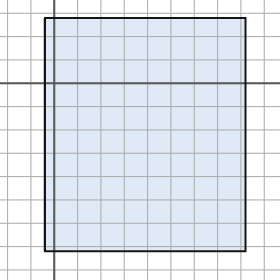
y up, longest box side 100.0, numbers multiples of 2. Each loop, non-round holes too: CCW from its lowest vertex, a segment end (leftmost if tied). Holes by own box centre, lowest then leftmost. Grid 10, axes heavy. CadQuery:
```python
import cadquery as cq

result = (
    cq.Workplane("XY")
    .moveTo(-4.0, -72.0)
    .lineTo(82.0, -72.0)
    .lineTo(82.0, 28.0)
    .lineTo(-4.0, 28.0)
    .close()
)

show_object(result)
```